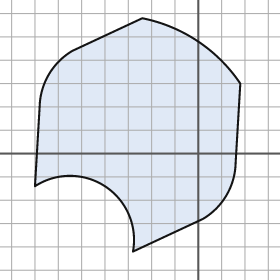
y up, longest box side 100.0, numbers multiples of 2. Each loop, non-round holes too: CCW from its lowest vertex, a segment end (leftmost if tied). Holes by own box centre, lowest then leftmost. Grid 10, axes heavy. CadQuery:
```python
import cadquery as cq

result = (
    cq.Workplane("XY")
    .moveTo(-28.0, -42.0)
    .lineTo(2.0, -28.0)
    .threePointArc((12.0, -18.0), (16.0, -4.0))
    .lineTo(18.0, 30.0)
    .threePointArc((0.0, 48.0), (-24.0, 58.0))
    .lineTo(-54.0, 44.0)
    .threePointArc((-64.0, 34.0), (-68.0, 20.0))
    .lineTo(-70.0, -14.0)
    .threePointArc((-40.0, -14.0), (-28.0, -42.0))
    .close()
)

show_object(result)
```